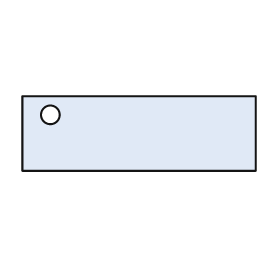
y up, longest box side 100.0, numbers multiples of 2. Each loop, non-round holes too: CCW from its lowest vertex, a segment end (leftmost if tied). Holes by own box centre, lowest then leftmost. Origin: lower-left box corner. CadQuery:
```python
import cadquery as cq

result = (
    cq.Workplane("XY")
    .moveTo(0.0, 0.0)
    .lineTo(100.0, 0.0)
    .lineTo(100.0, 32.0)
    .lineTo(0.0, 32.0)
    .close()
    .moveTo(12.0, 24.0)
    .circle(4.0)
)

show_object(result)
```